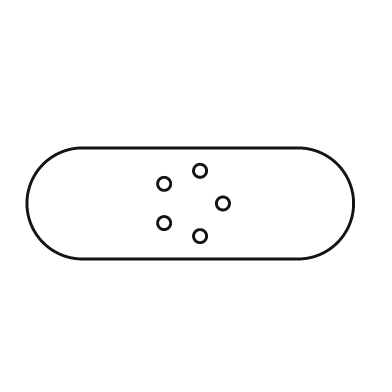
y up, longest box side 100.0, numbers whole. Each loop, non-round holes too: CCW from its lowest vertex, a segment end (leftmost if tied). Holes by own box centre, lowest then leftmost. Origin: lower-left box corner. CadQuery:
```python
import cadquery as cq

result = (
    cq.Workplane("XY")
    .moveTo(17.0, 0.0)
    .lineTo(83.0, 0.0)
    .threePointArc((100.0, 17.0), (83.0, 34.0))
    .lineTo(17.0, 34.0)
    .threePointArc((0.0, 17.0), (17.0, 0.0))
    .close()
    .moveTo(53.0, 7.0)
    .circle(2.0)
    .moveTo(42.0, 11.0)
    .circle(2.0)
    .moveTo(60.0, 17.0)
    .circle(2.0)
    .moveTo(42.0, 23.0)
    .circle(2.0)
    .moveTo(53.0, 27.0)
    .circle(2.0)
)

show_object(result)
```